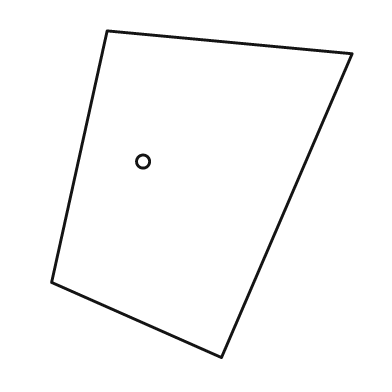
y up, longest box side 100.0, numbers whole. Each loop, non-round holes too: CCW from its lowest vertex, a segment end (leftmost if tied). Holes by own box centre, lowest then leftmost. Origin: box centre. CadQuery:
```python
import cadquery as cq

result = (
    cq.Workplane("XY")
    .moveTo(6.0, -50.0)
    .lineTo(46.0, 43.0)
    .lineTo(-29.0, 50.0)
    .lineTo(-46.0, -27.0)
    .close()
    .moveTo(-18.0, 10.0)
    .circle(2.0)
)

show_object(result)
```